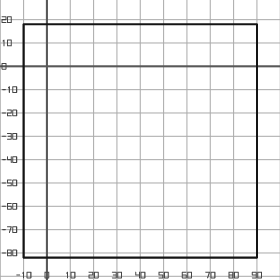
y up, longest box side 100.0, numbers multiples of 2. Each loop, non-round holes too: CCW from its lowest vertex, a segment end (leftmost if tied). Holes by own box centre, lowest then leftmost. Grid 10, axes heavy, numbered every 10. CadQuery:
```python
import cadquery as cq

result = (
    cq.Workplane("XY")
    .moveTo(-10.0, -82.0)
    .lineTo(90.0, -82.0)
    .lineTo(90.0, 18.0)
    .lineTo(-10.0, 18.0)
    .close()
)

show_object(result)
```